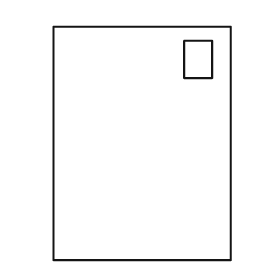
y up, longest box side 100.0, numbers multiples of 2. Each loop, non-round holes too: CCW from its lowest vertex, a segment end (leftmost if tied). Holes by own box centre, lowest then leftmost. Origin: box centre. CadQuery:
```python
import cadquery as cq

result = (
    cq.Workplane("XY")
    .moveTo(-38.0, -50.0)
    .lineTo(38.0, -50.0)
    .lineTo(38.0, 50.0)
    .lineTo(-38.0, 50.0)
    .close()
    .moveTo(18.0, 28.0)
    .lineTo(30.0, 28.0)
    .lineTo(30.0, 44.0)
    .lineTo(18.0, 44.0)
    .close()
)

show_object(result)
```